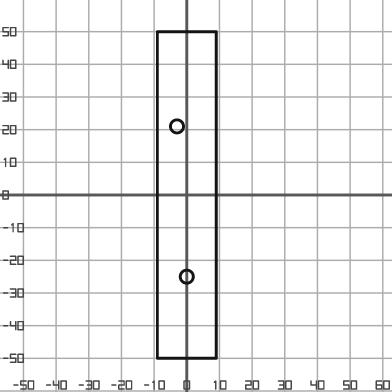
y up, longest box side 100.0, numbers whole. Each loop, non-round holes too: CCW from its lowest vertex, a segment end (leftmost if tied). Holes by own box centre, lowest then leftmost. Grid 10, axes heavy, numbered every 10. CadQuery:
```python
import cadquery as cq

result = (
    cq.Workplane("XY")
    .moveTo(-9.0, -50.0)
    .lineTo(9.0, -50.0)
    .lineTo(9.0, 50.0)
    .lineTo(-9.0, 50.0)
    .close()
    .moveTo(0.0, -25.0)
    .circle(2.0)
    .moveTo(-3.0, 21.0)
    .circle(2.0)
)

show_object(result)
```